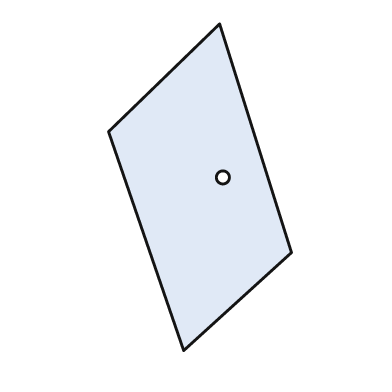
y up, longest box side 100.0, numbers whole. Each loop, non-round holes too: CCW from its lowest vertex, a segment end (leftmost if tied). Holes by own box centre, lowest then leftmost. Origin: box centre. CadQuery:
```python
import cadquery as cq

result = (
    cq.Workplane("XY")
    .moveTo(-5.0, -50.0)
    .lineTo(28.0, -20.0)
    .lineTo(6.0, 50.0)
    .lineTo(-28.0, 17.0)
    .close()
    .moveTo(7.0, 3.0)
    .circle(2.0)
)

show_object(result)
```